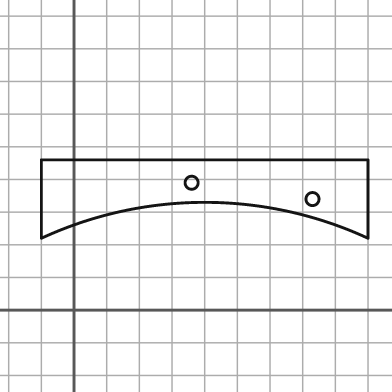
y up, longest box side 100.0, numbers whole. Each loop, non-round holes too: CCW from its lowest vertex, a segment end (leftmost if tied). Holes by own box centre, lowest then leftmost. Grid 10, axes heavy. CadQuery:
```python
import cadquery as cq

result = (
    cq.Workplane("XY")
    .moveTo(-10.0, 22.0)
    .threePointArc((40.0, 33.0), (90.0, 22.0))
    .lineTo(90.0, 46.0)
    .lineTo(-10.0, 46.0)
    .close()
    .moveTo(73.0, 34.0)
    .circle(2.0)
    .moveTo(36.0, 39.0)
    .circle(2.0)
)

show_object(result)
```